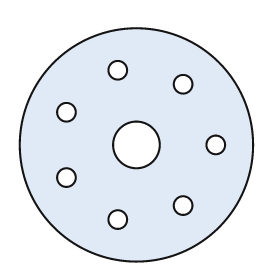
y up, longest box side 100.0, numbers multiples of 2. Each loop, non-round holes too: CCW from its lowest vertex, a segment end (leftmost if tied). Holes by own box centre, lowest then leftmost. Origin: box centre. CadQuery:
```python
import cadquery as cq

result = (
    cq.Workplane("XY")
    .moveTo(0.0, 0.0)
    .circle(50.0)
    .moveTo(-8.0, -32.0)
    .circle(4.0)
    .moveTo(20.0, -26.0)
    .circle(4.0)
    .moveTo(-30.0, -14.0)
    .circle(4.0)
    .moveTo(0.0, 0.0)
    .circle(10.0)
    .moveTo(34.0, 0.0)
    .circle(4.0)
    .moveTo(-30.0, 14.0)
    .circle(4.0)
    .moveTo(20.0, 26.0)
    .circle(4.0)
    .moveTo(-8.0, 32.0)
    .circle(4.0)
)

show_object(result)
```